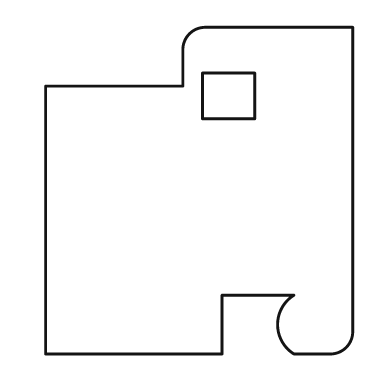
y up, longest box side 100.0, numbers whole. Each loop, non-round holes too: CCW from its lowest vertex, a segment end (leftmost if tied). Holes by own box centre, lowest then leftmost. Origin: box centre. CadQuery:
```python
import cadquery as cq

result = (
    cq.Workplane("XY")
    .moveTo(-47.0, -50.0)
    .lineTo(7.0, -50.0)
    .lineTo(7.0, -32.0)
    .lineTo(29.0, -32.0)
    .threePointArc((24.0, -41.0), (29.0, -50.0))
    .lineTo(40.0, -50.0)
    .threePointArc((45.0, -48.0), (47.0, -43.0))
    .lineTo(47.0, 50.0)
    .lineTo(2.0, 50.0)
    .threePointArc((-3.0, 48.0), (-5.0, 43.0))
    .lineTo(-5.0, 32.0)
    .lineTo(-47.0, 32.0)
    .close()
    .moveTo(1.0, 22.0)
    .lineTo(17.0, 22.0)
    .lineTo(17.0, 36.0)
    .lineTo(1.0, 36.0)
    .close()
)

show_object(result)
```